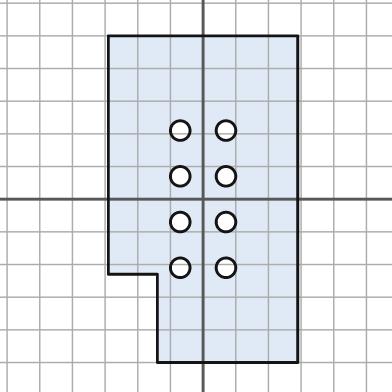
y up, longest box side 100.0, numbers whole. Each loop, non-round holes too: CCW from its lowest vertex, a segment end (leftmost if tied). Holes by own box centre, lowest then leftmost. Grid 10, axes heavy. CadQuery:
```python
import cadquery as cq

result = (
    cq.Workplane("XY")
    .moveTo(-14.0, -50.0)
    .lineTo(29.0, -50.0)
    .lineTo(29.0, 50.0)
    .lineTo(-29.0, 50.0)
    .lineTo(-29.0, -23.0)
    .lineTo(-14.0, -23.0)
    .close()
    .moveTo(-7.0, -21.0)
    .circle(3.0)
    .moveTo(7.0, -21.0)
    .circle(3.0)
    .moveTo(-7.0, -7.0)
    .circle(3.0)
    .moveTo(7.0, -7.0)
    .circle(3.0)
    .moveTo(-7.0, 7.0)
    .circle(3.0)
    .moveTo(7.0, 7.0)
    .circle(3.0)
    .moveTo(-7.0, 21.0)
    .circle(3.0)
    .moveTo(7.0, 21.0)
    .circle(3.0)
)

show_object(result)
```